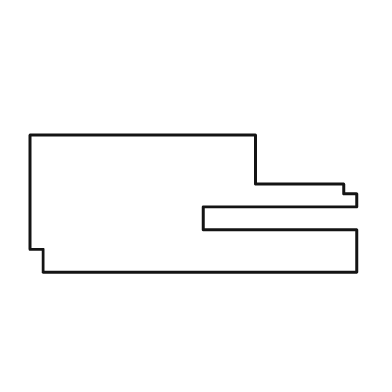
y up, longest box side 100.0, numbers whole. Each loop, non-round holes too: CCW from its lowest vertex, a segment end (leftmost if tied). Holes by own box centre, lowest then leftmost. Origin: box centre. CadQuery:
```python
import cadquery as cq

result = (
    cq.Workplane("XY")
    .moveTo(-46.0, -21.0)
    .lineTo(50.0, -21.0)
    .lineTo(50.0, -8.0)
    .lineTo(3.0, -8.0)
    .lineTo(3.0, -1.0)
    .lineTo(50.0, -1.0)
    .lineTo(50.0, 3.0)
    .lineTo(46.0, 3.0)
    .lineTo(46.0, 6.0)
    .lineTo(19.0, 6.0)
    .lineTo(19.0, 21.0)
    .lineTo(-50.0, 21.0)
    .lineTo(-50.0, -14.0)
    .lineTo(-46.0, -14.0)
    .close()
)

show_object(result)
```